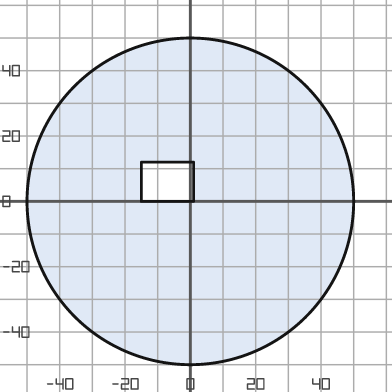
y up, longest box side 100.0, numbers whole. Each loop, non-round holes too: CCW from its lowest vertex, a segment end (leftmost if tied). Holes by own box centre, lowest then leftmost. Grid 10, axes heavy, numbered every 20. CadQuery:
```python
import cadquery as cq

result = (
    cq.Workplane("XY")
    .moveTo(0.0, 0.0)
    .circle(50.0)
    .moveTo(-15.0, 0.0)
    .lineTo(1.0, 0.0)
    .lineTo(1.0, 12.0)
    .lineTo(-15.0, 12.0)
    .close()
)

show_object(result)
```